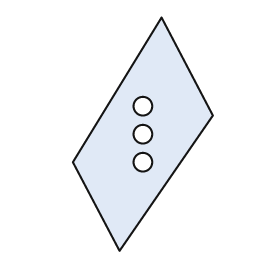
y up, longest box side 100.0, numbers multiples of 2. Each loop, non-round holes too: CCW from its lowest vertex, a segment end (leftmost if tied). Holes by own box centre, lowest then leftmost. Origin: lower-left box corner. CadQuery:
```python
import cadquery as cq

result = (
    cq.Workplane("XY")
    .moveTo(20.0, 0.0)
    .lineTo(60.0, 58.0)
    .lineTo(38.0, 100.0)
    .lineTo(0.0, 38.0)
    .close()
    .moveTo(30.0, 38.0)
    .circle(4.0)
    .moveTo(30.0, 50.0)
    .circle(4.0)
    .moveTo(30.0, 62.0)
    .circle(4.0)
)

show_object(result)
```